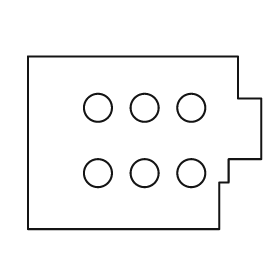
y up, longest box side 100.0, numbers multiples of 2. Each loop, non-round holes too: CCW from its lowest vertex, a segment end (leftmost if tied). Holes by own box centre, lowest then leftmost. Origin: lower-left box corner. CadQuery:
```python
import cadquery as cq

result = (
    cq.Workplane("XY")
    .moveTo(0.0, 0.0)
    .lineTo(82.0, 0.0)
    .lineTo(82.0, 20.0)
    .lineTo(86.0, 20.0)
    .lineTo(86.0, 30.0)
    .lineTo(100.0, 30.0)
    .lineTo(100.0, 56.0)
    .lineTo(90.0, 56.0)
    .lineTo(90.0, 74.0)
    .lineTo(0.0, 74.0)
    .close()
    .moveTo(30.0, 24.0)
    .circle(6.0)
    .moveTo(50.0, 24.0)
    .circle(6.0)
    .moveTo(70.0, 24.0)
    .circle(6.0)
    .moveTo(30.0, 52.0)
    .circle(6.0)
    .moveTo(50.0, 52.0)
    .circle(6.0)
    .moveTo(70.0, 52.0)
    .circle(6.0)
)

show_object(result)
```